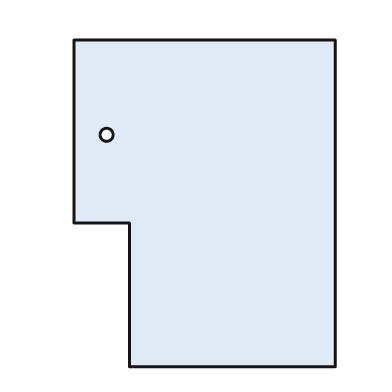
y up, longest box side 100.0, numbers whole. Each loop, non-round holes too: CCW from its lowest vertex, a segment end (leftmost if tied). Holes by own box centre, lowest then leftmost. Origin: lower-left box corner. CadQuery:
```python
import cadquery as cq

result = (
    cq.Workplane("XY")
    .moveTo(17.0, 0.0)
    .lineTo(80.0, 0.0)
    .lineTo(80.0, 100.0)
    .lineTo(0.0, 100.0)
    .lineTo(0.0, 44.0)
    .lineTo(17.0, 44.0)
    .close()
    .moveTo(10.0, 71.0)
    .circle(2.0)
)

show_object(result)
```